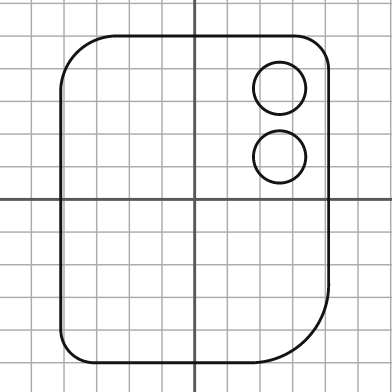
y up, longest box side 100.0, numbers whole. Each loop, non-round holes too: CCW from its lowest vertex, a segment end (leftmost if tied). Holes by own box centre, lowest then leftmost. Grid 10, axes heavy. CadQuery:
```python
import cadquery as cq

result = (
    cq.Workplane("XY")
    .moveTo(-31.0, -50.0)
    .lineTo(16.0, -50.0)
    .threePointArc((34.0, -43.0), (41.0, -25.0))
    .lineTo(41.0, 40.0)
    .threePointArc((38.0, 47.0), (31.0, 50.0))
    .lineTo(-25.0, 50.0)
    .threePointArc((-36.0, 45.0), (-41.0, 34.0))
    .lineTo(-41.0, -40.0)
    .threePointArc((-38.0, -47.0), (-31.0, -50.0))
    .close()
    .moveTo(26.0, 13.0)
    .circle(8.0)
    .moveTo(26.0, 34.0)
    .circle(8.0)
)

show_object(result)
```